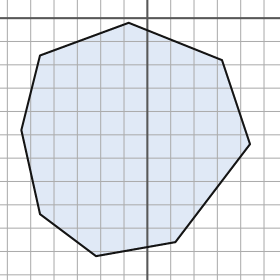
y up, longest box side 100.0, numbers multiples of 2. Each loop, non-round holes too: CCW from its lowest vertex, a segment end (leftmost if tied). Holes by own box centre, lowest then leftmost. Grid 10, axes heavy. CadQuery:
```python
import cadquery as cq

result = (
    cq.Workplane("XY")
    .moveTo(-22.0, -102.0)
    .lineTo(12.0, -96.0)
    .lineTo(44.0, -54.0)
    .lineTo(32.0, -18.0)
    .lineTo(-8.0, -2.0)
    .lineTo(-46.0, -16.0)
    .lineTo(-54.0, -48.0)
    .lineTo(-46.0, -84.0)
    .close()
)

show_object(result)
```